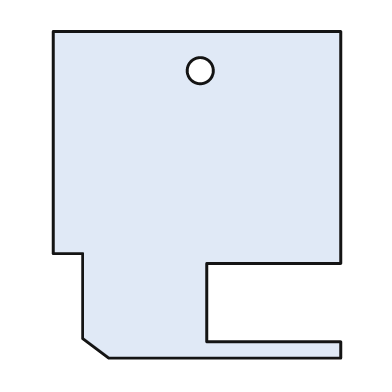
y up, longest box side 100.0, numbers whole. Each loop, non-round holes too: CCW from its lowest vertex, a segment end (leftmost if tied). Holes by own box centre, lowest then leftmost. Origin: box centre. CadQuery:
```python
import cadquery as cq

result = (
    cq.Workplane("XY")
    .moveTo(-27.0, -50.0)
    .lineTo(44.0, -50.0)
    .lineTo(44.0, -45.0)
    .lineTo(3.0, -45.0)
    .lineTo(3.0, -21.0)
    .lineTo(44.0, -21.0)
    .lineTo(44.0, 50.0)
    .lineTo(-44.0, 50.0)
    .lineTo(-44.0, -18.0)
    .lineTo(-35.0, -18.0)
    .lineTo(-35.0, -44.0)
    .close()
    .moveTo(1.0, 38.0)
    .circle(4.0)
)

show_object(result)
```